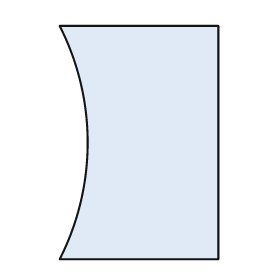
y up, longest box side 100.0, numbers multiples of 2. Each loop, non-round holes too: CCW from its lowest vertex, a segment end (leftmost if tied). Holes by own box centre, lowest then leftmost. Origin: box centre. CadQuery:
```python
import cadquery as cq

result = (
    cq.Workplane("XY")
    .moveTo(-34.0, -50.0)
    .lineTo(34.0, -50.0)
    .lineTo(34.0, 50.0)
    .lineTo(-34.0, 50.0)
    .threePointArc((-22.0, 0.0), (-34.0, -50.0))
    .close()
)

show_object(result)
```